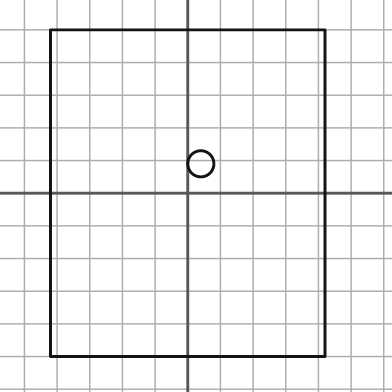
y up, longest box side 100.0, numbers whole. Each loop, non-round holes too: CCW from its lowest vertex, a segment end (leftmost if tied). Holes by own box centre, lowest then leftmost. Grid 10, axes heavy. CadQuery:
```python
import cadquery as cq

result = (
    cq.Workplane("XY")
    .moveTo(-42.0, -50.0)
    .lineTo(42.0, -50.0)
    .lineTo(42.0, 50.0)
    .lineTo(-42.0, 50.0)
    .close()
    .moveTo(4.0, 9.0)
    .circle(4.0)
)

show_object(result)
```